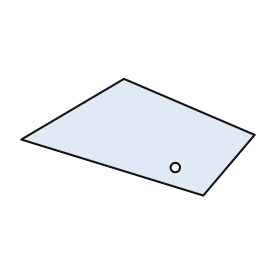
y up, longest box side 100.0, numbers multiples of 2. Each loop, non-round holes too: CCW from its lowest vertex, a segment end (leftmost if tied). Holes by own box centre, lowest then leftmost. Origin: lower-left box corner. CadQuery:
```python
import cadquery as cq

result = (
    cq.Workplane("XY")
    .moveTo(78.0, 0.0)
    .lineTo(100.0, 26.0)
    .lineTo(44.0, 50.0)
    .lineTo(0.0, 24.0)
    .close()
    .moveTo(66.0, 12.0)
    .circle(2.0)
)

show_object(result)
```